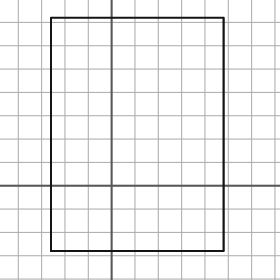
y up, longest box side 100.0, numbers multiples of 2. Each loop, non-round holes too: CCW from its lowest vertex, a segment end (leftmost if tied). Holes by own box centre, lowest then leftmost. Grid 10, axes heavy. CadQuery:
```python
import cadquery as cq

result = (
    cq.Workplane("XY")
    .moveTo(-26.0, -28.0)
    .lineTo(48.0, -28.0)
    .lineTo(48.0, 72.0)
    .lineTo(-26.0, 72.0)
    .close()
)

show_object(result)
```